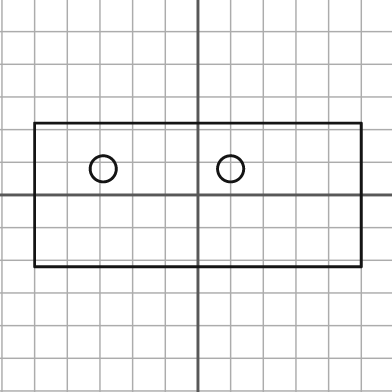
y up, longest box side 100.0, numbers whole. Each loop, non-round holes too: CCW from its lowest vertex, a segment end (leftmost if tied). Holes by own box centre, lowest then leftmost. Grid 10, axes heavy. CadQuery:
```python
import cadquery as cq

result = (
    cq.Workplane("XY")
    .moveTo(-50.0, -22.0)
    .lineTo(50.0, -22.0)
    .lineTo(50.0, 22.0)
    .lineTo(-50.0, 22.0)
    .close()
    .moveTo(-29.0, 8.0)
    .circle(4.0)
    .moveTo(10.0, 8.0)
    .circle(4.0)
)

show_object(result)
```